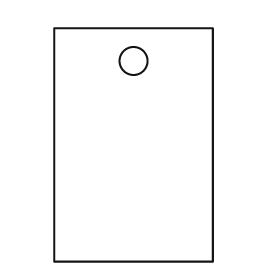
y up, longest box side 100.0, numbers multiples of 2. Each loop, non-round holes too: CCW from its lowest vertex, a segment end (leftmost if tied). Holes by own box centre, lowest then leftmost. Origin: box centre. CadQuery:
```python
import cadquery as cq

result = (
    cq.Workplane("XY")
    .moveTo(-34.0, -50.0)
    .lineTo(34.0, -50.0)
    .lineTo(34.0, 50.0)
    .lineTo(-34.0, 50.0)
    .close()
    .moveTo(0.0, 36.0)
    .circle(6.0)
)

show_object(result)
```